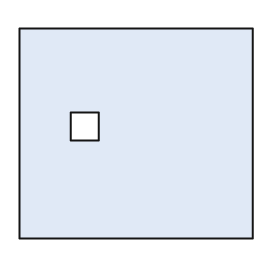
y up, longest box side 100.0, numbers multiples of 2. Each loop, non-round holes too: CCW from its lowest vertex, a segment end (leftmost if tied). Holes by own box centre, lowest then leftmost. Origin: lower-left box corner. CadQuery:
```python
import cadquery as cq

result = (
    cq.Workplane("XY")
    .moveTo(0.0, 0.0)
    .lineTo(100.0, 0.0)
    .lineTo(100.0, 90.0)
    .lineTo(0.0, 90.0)
    .close()
    .moveTo(22.0, 42.0)
    .lineTo(34.0, 42.0)
    .lineTo(34.0, 54.0)
    .lineTo(22.0, 54.0)
    .close()
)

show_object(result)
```